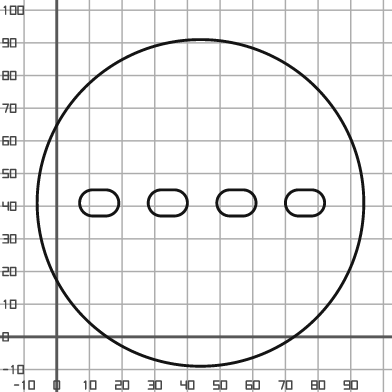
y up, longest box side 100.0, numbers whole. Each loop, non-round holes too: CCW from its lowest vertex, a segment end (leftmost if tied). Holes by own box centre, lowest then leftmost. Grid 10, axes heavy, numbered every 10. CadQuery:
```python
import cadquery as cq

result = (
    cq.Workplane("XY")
    .moveTo(44.0, 41.0)
    .circle(50.0)
    .moveTo(11.0, 37.0)
    .lineTo(15.0, 37.0)
    .threePointArc((19.0, 41.0), (15.0, 45.0))
    .lineTo(11.0, 45.0)
    .threePointArc((7.0, 41.0), (11.0, 37.0))
    .close()
    .moveTo(32.0, 37.0)
    .lineTo(36.0, 37.0)
    .threePointArc((40.0, 41.0), (36.0, 45.0))
    .lineTo(32.0, 45.0)
    .threePointArc((28.0, 41.0), (32.0, 37.0))
    .close()
    .moveTo(53.0, 37.0)
    .lineTo(57.0, 37.0)
    .threePointArc((61.0, 41.0), (57.0, 45.0))
    .lineTo(53.0, 45.0)
    .threePointArc((49.0, 41.0), (53.0, 37.0))
    .close()
    .moveTo(74.0, 37.0)
    .lineTo(78.0, 37.0)
    .threePointArc((82.0, 41.0), (78.0, 45.0))
    .lineTo(74.0, 45.0)
    .threePointArc((70.0, 41.0), (74.0, 37.0))
    .close()
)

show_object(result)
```